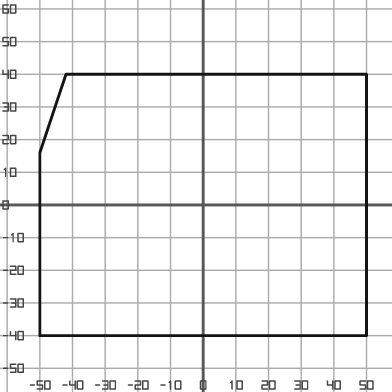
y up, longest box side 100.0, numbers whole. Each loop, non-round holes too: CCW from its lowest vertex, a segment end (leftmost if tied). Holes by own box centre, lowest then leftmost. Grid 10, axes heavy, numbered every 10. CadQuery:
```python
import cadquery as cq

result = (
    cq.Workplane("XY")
    .moveTo(-50.0, -40.0)
    .lineTo(50.0, -40.0)
    .lineTo(50.0, 40.0)
    .lineTo(-42.0, 40.0)
    .lineTo(-50.0, 16.0)
    .close()
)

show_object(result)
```